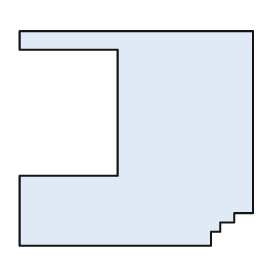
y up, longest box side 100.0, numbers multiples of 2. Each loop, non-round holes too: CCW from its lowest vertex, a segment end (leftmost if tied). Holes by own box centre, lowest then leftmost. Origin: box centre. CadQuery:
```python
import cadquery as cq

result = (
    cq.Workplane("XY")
    .moveTo(-50.0, -46.0)
    .lineTo(32.0, -46.0)
    .lineTo(32.0, -40.0)
    .lineTo(36.0, -40.0)
    .lineTo(36.0, -36.0)
    .lineTo(42.0, -36.0)
    .lineTo(42.0, -32.0)
    .lineTo(50.0, -32.0)
    .lineTo(50.0, 46.0)
    .lineTo(-50.0, 46.0)
    .lineTo(-50.0, 38.0)
    .lineTo(-8.0, 38.0)
    .lineTo(-8.0, -16.0)
    .lineTo(-50.0, -16.0)
    .close()
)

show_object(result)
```